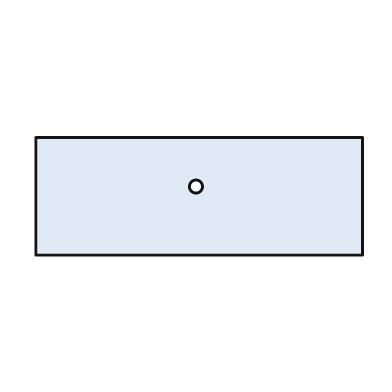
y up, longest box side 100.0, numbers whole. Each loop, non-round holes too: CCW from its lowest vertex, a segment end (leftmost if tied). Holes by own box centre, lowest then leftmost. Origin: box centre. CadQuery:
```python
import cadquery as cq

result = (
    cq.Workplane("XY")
    .moveTo(-50.0, -18.0)
    .lineTo(50.0, -18.0)
    .lineTo(50.0, 18.0)
    .lineTo(-50.0, 18.0)
    .close()
    .moveTo(-1.0, 3.0)
    .circle(2.0)
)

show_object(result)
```